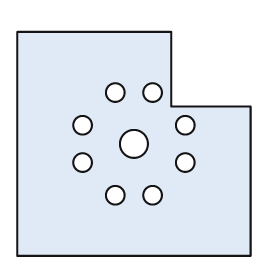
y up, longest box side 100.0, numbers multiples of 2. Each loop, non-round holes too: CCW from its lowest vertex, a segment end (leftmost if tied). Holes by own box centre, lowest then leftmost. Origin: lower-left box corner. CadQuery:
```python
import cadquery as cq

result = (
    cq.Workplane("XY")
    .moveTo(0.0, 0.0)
    .lineTo(100.0, 0.0)
    .lineTo(100.0, 64.0)
    .lineTo(66.0, 64.0)
    .lineTo(66.0, 96.0)
    .lineTo(0.0, 96.0)
    .close()
    .moveTo(42.0, 26.0)
    .circle(4.0)
    .moveTo(58.0, 26.0)
    .circle(4.0)
    .moveTo(28.0, 40.0)
    .circle(4.0)
    .moveTo(72.0, 40.0)
    .circle(4.0)
    .moveTo(50.0, 48.0)
    .circle(6.0)
    .moveTo(28.0, 56.0)
    .circle(4.0)
    .moveTo(72.0, 56.0)
    .circle(4.0)
    .moveTo(42.0, 70.0)
    .circle(4.0)
    .moveTo(58.0, 70.0)
    .circle(4.0)
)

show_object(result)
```